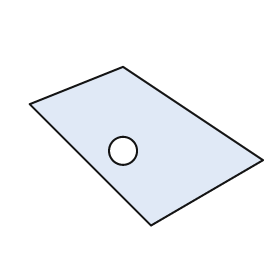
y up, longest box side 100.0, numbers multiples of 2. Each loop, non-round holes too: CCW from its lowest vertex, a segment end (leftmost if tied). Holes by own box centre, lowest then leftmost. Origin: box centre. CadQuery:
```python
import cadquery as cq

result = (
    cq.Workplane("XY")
    .moveTo(2.0, -34.0)
    .lineTo(50.0, -6.0)
    .lineTo(-10.0, 34.0)
    .lineTo(-50.0, 18.0)
    .close()
    .moveTo(-10.0, -2.0)
    .circle(6.0)
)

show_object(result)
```